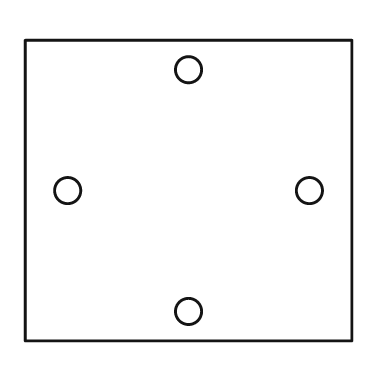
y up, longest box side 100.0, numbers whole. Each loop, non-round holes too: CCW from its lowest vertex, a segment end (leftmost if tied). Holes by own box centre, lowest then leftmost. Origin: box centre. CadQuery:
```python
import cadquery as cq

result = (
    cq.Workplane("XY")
    .moveTo(-50.0, -46.0)
    .lineTo(50.0, -46.0)
    .lineTo(50.0, 46.0)
    .lineTo(-50.0, 46.0)
    .close()
    .moveTo(0.0, -37.0)
    .circle(4.0)
    .moveTo(-37.0, 0.0)
    .circle(4.0)
    .moveTo(37.0, 0.0)
    .circle(4.0)
    .moveTo(0.0, 37.0)
    .circle(4.0)
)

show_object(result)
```